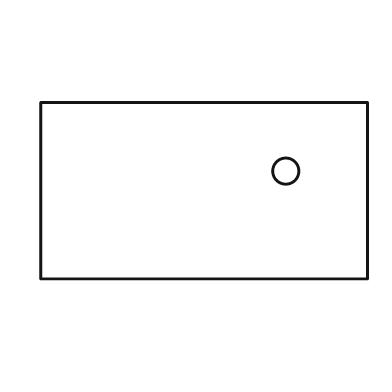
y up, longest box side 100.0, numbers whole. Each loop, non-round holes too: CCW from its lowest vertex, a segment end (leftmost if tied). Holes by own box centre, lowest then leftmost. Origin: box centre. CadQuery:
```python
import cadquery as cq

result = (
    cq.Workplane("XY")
    .moveTo(-50.0, -27.0)
    .lineTo(50.0, -27.0)
    .lineTo(50.0, 27.0)
    .lineTo(-50.0, 27.0)
    .close()
    .moveTo(25.0, 6.0)
    .circle(4.0)
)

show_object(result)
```